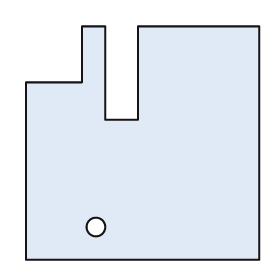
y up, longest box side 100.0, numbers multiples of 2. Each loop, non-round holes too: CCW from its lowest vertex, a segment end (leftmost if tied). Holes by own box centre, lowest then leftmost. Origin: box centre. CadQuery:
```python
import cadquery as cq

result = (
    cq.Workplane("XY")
    .moveTo(-50.0, -50.0)
    .lineTo(50.0, -50.0)
    .lineTo(50.0, 50.0)
    .lineTo(-2.0, 50.0)
    .lineTo(-2.0, 10.0)
    .lineTo(-16.0, 10.0)
    .lineTo(-16.0, 50.0)
    .lineTo(-26.0, 50.0)
    .lineTo(-26.0, 26.0)
    .lineTo(-50.0, 26.0)
    .close()
    .moveTo(-20.0, -36.0)
    .circle(4.0)
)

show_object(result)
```